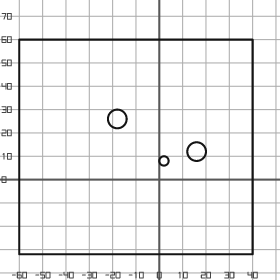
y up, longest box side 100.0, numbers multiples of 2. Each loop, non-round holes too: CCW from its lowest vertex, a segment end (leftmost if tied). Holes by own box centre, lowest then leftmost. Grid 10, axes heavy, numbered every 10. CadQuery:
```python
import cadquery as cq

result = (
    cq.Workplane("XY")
    .moveTo(-60.0, -32.0)
    .lineTo(40.0, -32.0)
    .lineTo(40.0, 60.0)
    .lineTo(-60.0, 60.0)
    .close()
    .moveTo(2.0, 8.0)
    .circle(2.0)
    .moveTo(16.0, 12.0)
    .circle(4.0)
    .moveTo(-18.0, 26.0)
    .circle(4.0)
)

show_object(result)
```